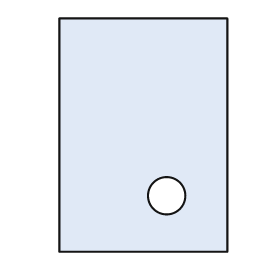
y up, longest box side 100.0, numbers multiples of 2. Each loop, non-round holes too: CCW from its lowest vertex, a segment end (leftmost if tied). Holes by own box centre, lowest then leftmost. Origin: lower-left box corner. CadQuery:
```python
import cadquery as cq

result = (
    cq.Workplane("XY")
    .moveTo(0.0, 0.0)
    .lineTo(72.0, 0.0)
    .lineTo(72.0, 100.0)
    .lineTo(0.0, 100.0)
    .close()
    .moveTo(46.0, 24.0)
    .circle(8.0)
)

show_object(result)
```